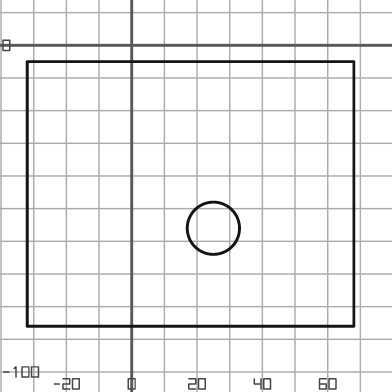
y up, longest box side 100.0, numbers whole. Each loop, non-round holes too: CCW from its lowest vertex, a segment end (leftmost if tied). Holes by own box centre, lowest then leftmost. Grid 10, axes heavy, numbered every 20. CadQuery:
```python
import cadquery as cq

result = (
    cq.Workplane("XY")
    .moveTo(-32.0, -86.0)
    .lineTo(68.0, -86.0)
    .lineTo(68.0, -5.0)
    .lineTo(-32.0, -5.0)
    .close()
    .moveTo(25.0, -56.0)
    .circle(8.0)
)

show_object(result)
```